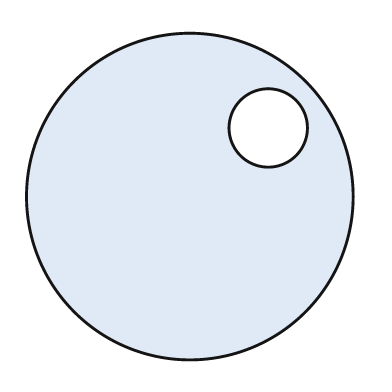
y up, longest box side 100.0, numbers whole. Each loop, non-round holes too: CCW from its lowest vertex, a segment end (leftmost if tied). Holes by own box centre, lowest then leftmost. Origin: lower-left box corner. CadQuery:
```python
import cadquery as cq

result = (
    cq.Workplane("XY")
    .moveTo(50.0, 50.0)
    .circle(50.0)
    .moveTo(74.0, 71.0)
    .circle(12.0)
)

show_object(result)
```